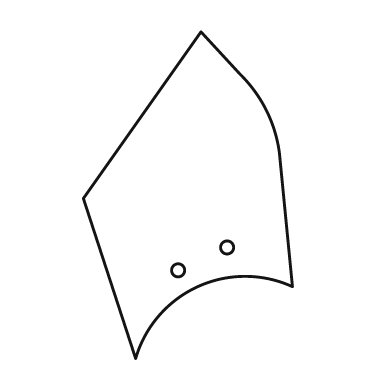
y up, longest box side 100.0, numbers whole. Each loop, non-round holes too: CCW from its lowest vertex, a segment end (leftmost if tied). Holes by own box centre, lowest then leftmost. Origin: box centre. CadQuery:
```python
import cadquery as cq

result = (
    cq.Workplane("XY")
    .moveTo(-16.0, -50.0)
    .threePointArc((3.0, -28.0), (32.0, -28.0))
    .lineTo(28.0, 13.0)
    .threePointArc((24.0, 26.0), (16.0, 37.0))
    .lineTo(4.0, 50.0)
    .lineTo(-32.0, -1.0)
    .close()
    .moveTo(-3.0, -23.0)
    .circle(2.0)
    .moveTo(12.0, -16.0)
    .circle(2.0)
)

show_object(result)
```